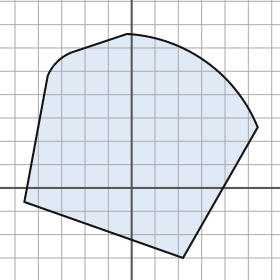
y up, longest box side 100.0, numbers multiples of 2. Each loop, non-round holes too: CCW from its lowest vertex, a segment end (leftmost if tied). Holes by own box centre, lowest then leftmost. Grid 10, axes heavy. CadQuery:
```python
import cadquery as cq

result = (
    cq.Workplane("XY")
    .moveTo(22.0, -30.0)
    .lineTo(54.0, 26.0)
    .threePointArc((32.0, 54.0), (-2.0, 66.0))
    .lineTo(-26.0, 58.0)
    .threePointArc((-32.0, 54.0), (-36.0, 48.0))
    .lineTo(-46.0, -6.0)
    .close()
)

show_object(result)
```